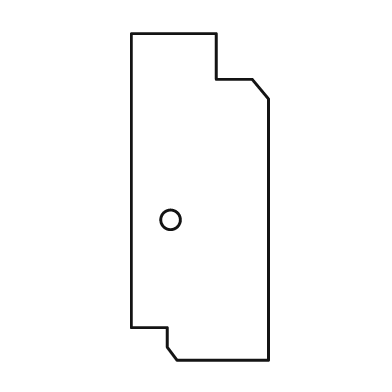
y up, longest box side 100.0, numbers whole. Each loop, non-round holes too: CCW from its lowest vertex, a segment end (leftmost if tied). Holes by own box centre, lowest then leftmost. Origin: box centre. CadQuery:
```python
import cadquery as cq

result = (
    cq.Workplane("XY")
    .moveTo(-7.0, -50.0)
    .lineTo(21.0, -50.0)
    .lineTo(21.0, 30.0)
    .lineTo(16.0, 36.0)
    .lineTo(5.0, 36.0)
    .lineTo(5.0, 50.0)
    .lineTo(-21.0, 50.0)
    .lineTo(-21.0, -40.0)
    .lineTo(-10.0, -40.0)
    .lineTo(-10.0, -46.0)
    .close()
    .moveTo(-9.0, -7.0)
    .circle(3.0)
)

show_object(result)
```